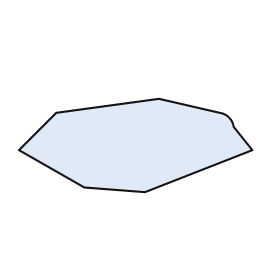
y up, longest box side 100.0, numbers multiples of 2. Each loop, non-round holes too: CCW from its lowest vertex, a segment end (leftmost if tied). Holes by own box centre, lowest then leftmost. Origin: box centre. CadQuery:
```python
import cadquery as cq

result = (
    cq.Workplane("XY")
    .moveTo(4.0, -20.0)
    .lineTo(50.0, -2.0)
    .lineTo(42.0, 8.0)
    .threePointArc((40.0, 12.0), (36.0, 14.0))
    .lineTo(10.0, 20.0)
    .lineTo(-34.0, 14.0)
    .lineTo(-50.0, -2.0)
    .lineTo(-22.0, -18.0)
    .close()
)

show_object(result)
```